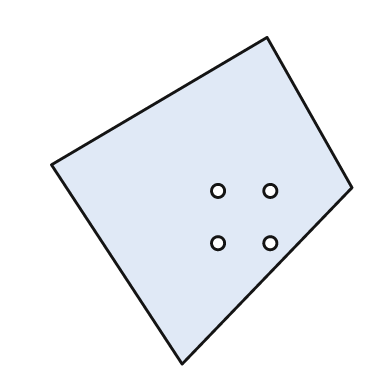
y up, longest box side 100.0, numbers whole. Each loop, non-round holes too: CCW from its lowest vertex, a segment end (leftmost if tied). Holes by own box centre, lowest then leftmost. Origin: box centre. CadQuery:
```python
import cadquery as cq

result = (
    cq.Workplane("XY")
    .moveTo(-6.0, -50.0)
    .lineTo(46.0, 4.0)
    .lineTo(20.0, 50.0)
    .lineTo(-46.0, 11.0)
    .close()
    .moveTo(5.0, -13.0)
    .circle(2.0)
    .moveTo(21.0, -13.0)
    .circle(2.0)
    .moveTo(5.0, 3.0)
    .circle(2.0)
    .moveTo(21.0, 3.0)
    .circle(2.0)
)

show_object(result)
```